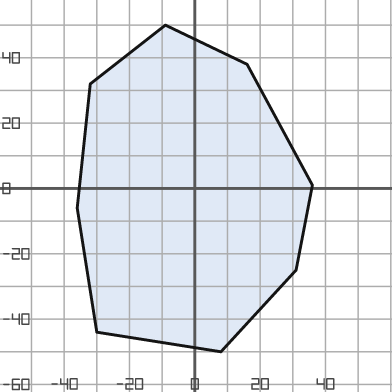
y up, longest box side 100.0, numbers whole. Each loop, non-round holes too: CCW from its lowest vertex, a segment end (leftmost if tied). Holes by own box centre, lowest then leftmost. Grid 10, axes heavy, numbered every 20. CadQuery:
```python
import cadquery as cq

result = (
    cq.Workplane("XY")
    .moveTo(8.0, -50.0)
    .lineTo(31.0, -25.0)
    .lineTo(36.0, 1.0)
    .lineTo(16.0, 38.0)
    .lineTo(-9.0, 50.0)
    .lineTo(-32.0, 32.0)
    .lineTo(-36.0, -6.0)
    .lineTo(-30.0, -44.0)
    .close()
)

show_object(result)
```